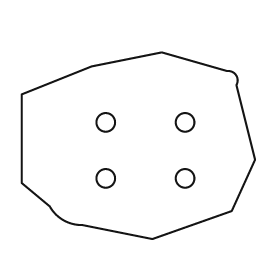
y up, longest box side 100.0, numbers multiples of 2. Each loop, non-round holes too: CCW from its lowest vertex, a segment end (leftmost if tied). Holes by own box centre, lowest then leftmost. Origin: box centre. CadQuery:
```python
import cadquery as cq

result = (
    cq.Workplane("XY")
    .moveTo(6.0, -40.0)
    .lineTo(40.0, -28.0)
    .lineTo(50.0, -6.0)
    .lineTo(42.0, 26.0)
    .threePointArc((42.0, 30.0), (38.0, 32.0))
    .lineTo(10.0, 40.0)
    .lineTo(-20.0, 34.0)
    .lineTo(-50.0, 22.0)
    .lineTo(-50.0, -16.0)
    .lineTo(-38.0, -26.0)
    .threePointArc((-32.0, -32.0), (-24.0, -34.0))
    .close()
    .moveTo(-14.0, -14.0)
    .circle(4.0)
    .moveTo(20.0, -14.0)
    .circle(4.0)
    .moveTo(-14.0, 10.0)
    .circle(4.0)
    .moveTo(20.0, 10.0)
    .circle(4.0)
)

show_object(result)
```